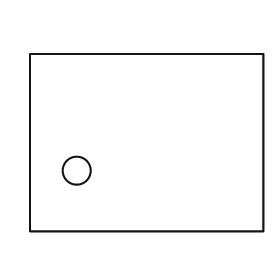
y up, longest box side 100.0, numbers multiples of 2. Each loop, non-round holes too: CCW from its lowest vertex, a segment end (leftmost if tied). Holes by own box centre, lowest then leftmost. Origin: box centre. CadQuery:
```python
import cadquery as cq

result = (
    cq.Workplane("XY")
    .moveTo(-50.0, -38.0)
    .lineTo(50.0, -38.0)
    .lineTo(50.0, 38.0)
    .lineTo(-50.0, 38.0)
    .close()
    .moveTo(-30.0, -12.0)
    .circle(6.0)
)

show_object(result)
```